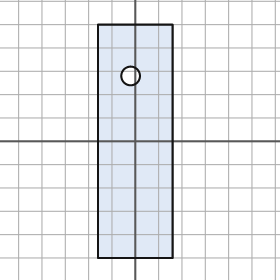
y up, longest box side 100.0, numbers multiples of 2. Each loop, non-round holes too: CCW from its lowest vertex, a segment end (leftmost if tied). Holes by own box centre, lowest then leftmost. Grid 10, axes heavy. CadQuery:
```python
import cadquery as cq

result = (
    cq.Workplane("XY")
    .moveTo(-16.0, -50.0)
    .lineTo(16.0, -50.0)
    .lineTo(16.0, 50.0)
    .lineTo(-16.0, 50.0)
    .close()
    .moveTo(-2.0, 28.0)
    .circle(4.0)
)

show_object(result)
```